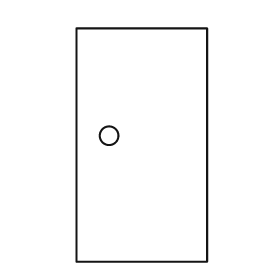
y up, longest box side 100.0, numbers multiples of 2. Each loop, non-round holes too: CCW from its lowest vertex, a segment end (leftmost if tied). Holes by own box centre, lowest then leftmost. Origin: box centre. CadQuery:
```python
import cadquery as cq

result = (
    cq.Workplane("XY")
    .moveTo(-28.0, -50.0)
    .lineTo(28.0, -50.0)
    .lineTo(28.0, 50.0)
    .lineTo(-28.0, 50.0)
    .close()
    .moveTo(-14.0, 4.0)
    .circle(4.0)
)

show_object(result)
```